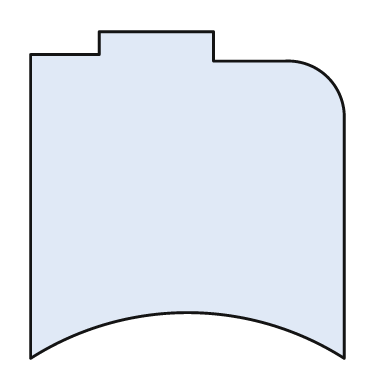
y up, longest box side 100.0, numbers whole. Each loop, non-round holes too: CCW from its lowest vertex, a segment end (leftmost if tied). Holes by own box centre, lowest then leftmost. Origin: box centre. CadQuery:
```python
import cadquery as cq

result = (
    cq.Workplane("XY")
    .moveTo(-48.0, -50.0)
    .threePointArc((0.0, -36.0), (48.0, -50.0))
    .lineTo(48.0, 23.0)
    .threePointArc((43.0, 36.0), (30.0, 41.0))
    .lineTo(8.0, 41.0)
    .lineTo(8.0, 50.0)
    .lineTo(-27.0, 50.0)
    .lineTo(-27.0, 43.0)
    .lineTo(-48.0, 43.0)
    .close()
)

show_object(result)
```